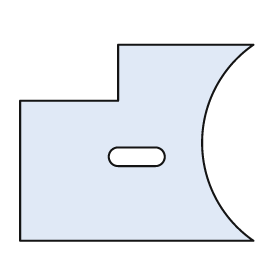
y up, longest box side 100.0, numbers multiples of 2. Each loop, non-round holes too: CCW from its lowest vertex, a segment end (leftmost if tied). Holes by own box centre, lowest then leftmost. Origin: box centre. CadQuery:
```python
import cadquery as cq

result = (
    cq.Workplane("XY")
    .moveTo(-50.0, -42.0)
    .lineTo(50.0, -42.0)
    .threePointArc((28.0, 0.0), (50.0, 42.0))
    .lineTo(-8.0, 42.0)
    .lineTo(-8.0, 18.0)
    .lineTo(-50.0, 18.0)
    .close()
    .moveTo(-8.0, -10.0)
    .lineTo(8.0, -10.0)
    .threePointArc((12.0, -6.0), (8.0, -2.0))
    .lineTo(-8.0, -2.0)
    .threePointArc((-12.0, -6.0), (-8.0, -10.0))
    .close()
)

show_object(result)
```